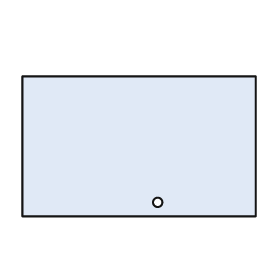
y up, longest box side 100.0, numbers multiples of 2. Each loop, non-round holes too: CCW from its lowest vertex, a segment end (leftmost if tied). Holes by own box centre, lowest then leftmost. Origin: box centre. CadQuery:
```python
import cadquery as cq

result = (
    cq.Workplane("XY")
    .moveTo(-50.0, -30.0)
    .lineTo(50.0, -30.0)
    .lineTo(50.0, 30.0)
    .lineTo(-50.0, 30.0)
    .close()
    .moveTo(8.0, -24.0)
    .circle(2.0)
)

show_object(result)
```